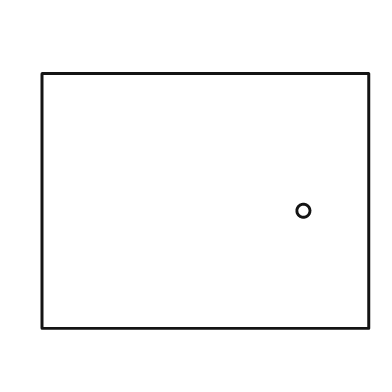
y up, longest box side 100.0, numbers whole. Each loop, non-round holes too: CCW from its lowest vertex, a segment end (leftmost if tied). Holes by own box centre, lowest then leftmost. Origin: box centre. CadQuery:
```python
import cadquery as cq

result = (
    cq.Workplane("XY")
    .moveTo(-50.0, -39.0)
    .lineTo(50.0, -39.0)
    .lineTo(50.0, 39.0)
    .lineTo(-50.0, 39.0)
    .close()
    .moveTo(30.0, -3.0)
    .circle(2.0)
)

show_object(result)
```